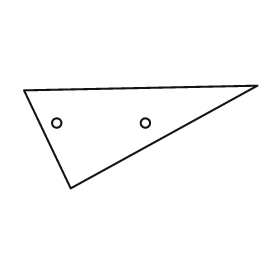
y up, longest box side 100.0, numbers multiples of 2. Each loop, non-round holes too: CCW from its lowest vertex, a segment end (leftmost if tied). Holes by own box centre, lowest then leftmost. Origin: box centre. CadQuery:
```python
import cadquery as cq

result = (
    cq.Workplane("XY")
    .moveTo(-30.0, -22.0)
    .lineTo(50.0, 22.0)
    .lineTo(-50.0, 20.0)
    .close()
    .moveTo(-36.0, 6.0)
    .circle(2.0)
    .moveTo(2.0, 6.0)
    .circle(2.0)
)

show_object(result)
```